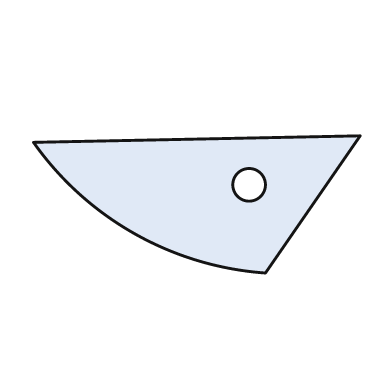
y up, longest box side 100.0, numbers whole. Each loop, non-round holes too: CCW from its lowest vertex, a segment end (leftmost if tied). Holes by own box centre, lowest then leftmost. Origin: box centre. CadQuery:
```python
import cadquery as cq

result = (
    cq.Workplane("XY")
    .moveTo(21.0, -21.0)
    .lineTo(50.0, 21.0)
    .lineTo(-50.0, 19.0)
    .threePointArc((-19.0, -9.0), (21.0, -21.0))
    .close()
    .moveTo(16.0, 6.0)
    .circle(5.0)
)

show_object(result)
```